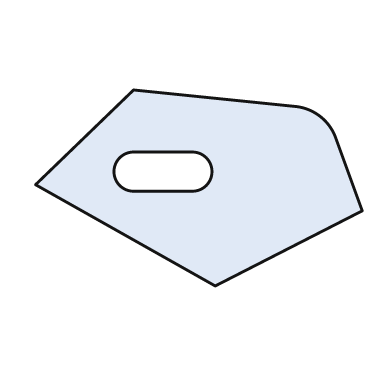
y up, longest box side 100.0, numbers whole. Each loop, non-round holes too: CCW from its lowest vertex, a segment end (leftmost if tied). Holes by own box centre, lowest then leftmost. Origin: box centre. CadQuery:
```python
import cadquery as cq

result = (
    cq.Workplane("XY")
    .moveTo(5.0, -30.0)
    .lineTo(50.0, -7.0)
    .lineTo(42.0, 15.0)
    .threePointArc((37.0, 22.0), (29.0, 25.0))
    .lineTo(-20.0, 30.0)
    .lineTo(-50.0, 1.0)
    .close()
    .moveTo(-20.0, -1.0)
    .lineTo(-2.0, -1.0)
    .threePointArc((4.0, 5.0), (-2.0, 11.0))
    .lineTo(-20.0, 11.0)
    .threePointArc((-26.0, 5.0), (-20.0, -1.0))
    .close()
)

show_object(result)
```